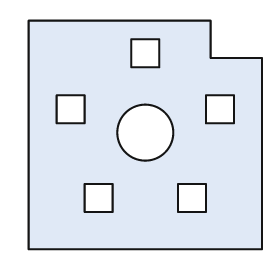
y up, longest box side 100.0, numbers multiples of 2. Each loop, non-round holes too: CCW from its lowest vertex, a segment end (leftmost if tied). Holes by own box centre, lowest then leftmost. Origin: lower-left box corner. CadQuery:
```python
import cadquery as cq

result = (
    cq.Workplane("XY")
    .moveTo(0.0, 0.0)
    .lineTo(100.0, 0.0)
    .lineTo(100.0, 82.0)
    .lineTo(78.0, 82.0)
    .lineTo(78.0, 98.0)
    .lineTo(0.0, 98.0)
    .close()
    .moveTo(24.0, 16.0)
    .lineTo(36.0, 16.0)
    .lineTo(36.0, 28.0)
    .lineTo(24.0, 28.0)
    .close()
    .moveTo(64.0, 16.0)
    .lineTo(76.0, 16.0)
    .lineTo(76.0, 28.0)
    .lineTo(64.0, 28.0)
    .close()
    .moveTo(50.0, 50.0)
    .circle(12.0)
    .moveTo(12.0, 54.0)
    .lineTo(24.0, 54.0)
    .lineTo(24.0, 66.0)
    .lineTo(12.0, 66.0)
    .close()
    .moveTo(76.0, 54.0)
    .lineTo(88.0, 54.0)
    .lineTo(88.0, 66.0)
    .lineTo(76.0, 66.0)
    .close()
    .moveTo(44.0, 78.0)
    .lineTo(56.0, 78.0)
    .lineTo(56.0, 90.0)
    .lineTo(44.0, 90.0)
    .close()
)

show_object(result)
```